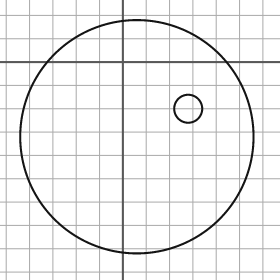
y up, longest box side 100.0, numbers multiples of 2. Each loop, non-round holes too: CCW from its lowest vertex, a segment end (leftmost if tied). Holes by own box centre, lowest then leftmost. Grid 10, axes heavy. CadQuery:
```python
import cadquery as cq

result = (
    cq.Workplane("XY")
    .moveTo(6.0, -32.0)
    .circle(50.0)
    .moveTo(28.0, -20.0)
    .circle(6.0)
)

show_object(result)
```